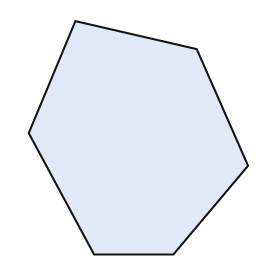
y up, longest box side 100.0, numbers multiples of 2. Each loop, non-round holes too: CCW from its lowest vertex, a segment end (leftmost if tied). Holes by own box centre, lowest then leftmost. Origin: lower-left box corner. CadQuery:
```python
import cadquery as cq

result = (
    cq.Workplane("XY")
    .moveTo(28.0, 0.0)
    .lineTo(62.0, 0.0)
    .lineTo(94.0, 38.0)
    .lineTo(72.0, 88.0)
    .lineTo(20.0, 100.0)
    .lineTo(0.0, 52.0)
    .close()
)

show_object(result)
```